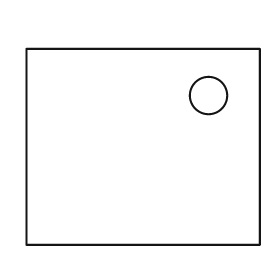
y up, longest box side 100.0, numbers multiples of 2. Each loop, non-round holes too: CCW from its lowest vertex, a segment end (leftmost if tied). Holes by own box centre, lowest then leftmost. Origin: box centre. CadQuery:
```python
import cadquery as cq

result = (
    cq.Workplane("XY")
    .moveTo(-50.0, -42.0)
    .lineTo(50.0, -42.0)
    .lineTo(50.0, 42.0)
    .lineTo(-50.0, 42.0)
    .close()
    .moveTo(28.0, 22.0)
    .circle(8.0)
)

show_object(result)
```